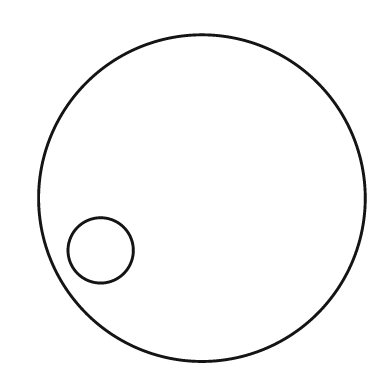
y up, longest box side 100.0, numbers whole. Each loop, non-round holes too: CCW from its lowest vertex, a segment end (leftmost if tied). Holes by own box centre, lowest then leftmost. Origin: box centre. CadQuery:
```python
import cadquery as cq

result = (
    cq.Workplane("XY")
    .moveTo(0.0, 0.0)
    .circle(50.0)
    .moveTo(-31.0, -16.0)
    .circle(10.0)
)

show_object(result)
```